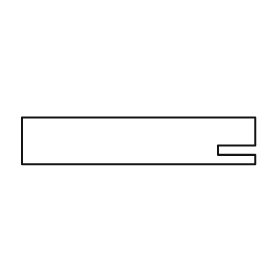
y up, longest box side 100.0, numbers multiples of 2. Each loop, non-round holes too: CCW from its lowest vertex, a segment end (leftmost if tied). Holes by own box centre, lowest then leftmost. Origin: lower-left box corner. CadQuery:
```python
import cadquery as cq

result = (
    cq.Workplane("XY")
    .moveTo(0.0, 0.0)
    .lineTo(100.0, 0.0)
    .lineTo(100.0, 4.0)
    .lineTo(84.0, 4.0)
    .lineTo(84.0, 8.0)
    .lineTo(100.0, 8.0)
    .lineTo(100.0, 20.0)
    .lineTo(0.0, 20.0)
    .close()
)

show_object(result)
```